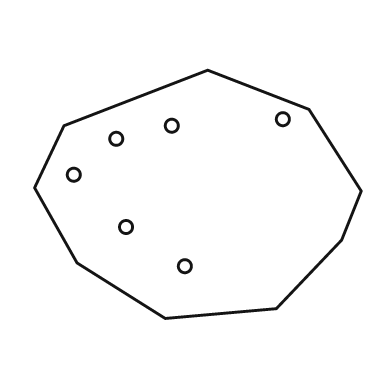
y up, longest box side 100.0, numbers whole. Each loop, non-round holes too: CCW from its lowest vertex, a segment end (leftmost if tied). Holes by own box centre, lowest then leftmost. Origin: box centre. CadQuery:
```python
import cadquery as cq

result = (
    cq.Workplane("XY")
    .moveTo(-10.0, -38.0)
    .lineTo(24.0, -35.0)
    .lineTo(44.0, -14.0)
    .lineTo(50.0, 1.0)
    .lineTo(34.0, 26.0)
    .lineTo(3.0, 38.0)
    .lineTo(-41.0, 21.0)
    .lineTo(-50.0, 2.0)
    .lineTo(-37.0, -21.0)
    .close()
    .moveTo(-4.0, -22.0)
    .circle(2.0)
    .moveTo(-22.0, -10.0)
    .circle(2.0)
    .moveTo(-38.0, 6.0)
    .circle(2.0)
    .moveTo(-25.0, 17.0)
    .circle(2.0)
    .moveTo(-8.0, 21.0)
    .circle(2.0)
    .moveTo(26.0, 23.0)
    .circle(2.0)
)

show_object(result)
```